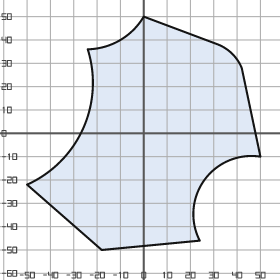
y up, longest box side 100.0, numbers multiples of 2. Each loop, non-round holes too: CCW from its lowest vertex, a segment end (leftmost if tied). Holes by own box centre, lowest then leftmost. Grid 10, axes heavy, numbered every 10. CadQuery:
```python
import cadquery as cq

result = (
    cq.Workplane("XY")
    .moveTo(-18.0, -50.0)
    .lineTo(24.0, -46.0)
    .threePointArc((26.0, -20.0), (50.0, -10.0))
    .lineTo(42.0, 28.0)
    .threePointArc((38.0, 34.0), (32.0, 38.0))
    .lineTo(0.0, 50.0)
    .threePointArc((-10.0, 40.0), (-24.0, 36.0))
    .threePointArc((-26.0, 2.0), (-50.0, -22.0))
    .close()
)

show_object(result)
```